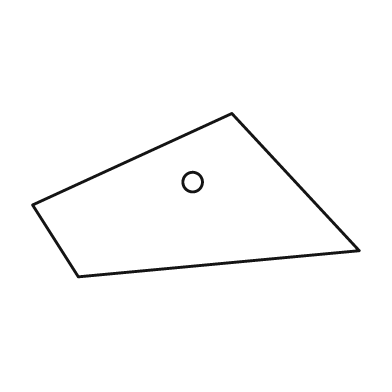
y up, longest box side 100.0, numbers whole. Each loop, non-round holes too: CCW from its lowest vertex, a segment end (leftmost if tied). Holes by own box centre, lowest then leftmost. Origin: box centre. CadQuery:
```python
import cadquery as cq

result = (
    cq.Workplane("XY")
    .moveTo(-36.0, -25.0)
    .lineTo(50.0, -17.0)
    .lineTo(11.0, 25.0)
    .lineTo(-50.0, -3.0)
    .close()
    .moveTo(-1.0, 4.0)
    .circle(3.0)
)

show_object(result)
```